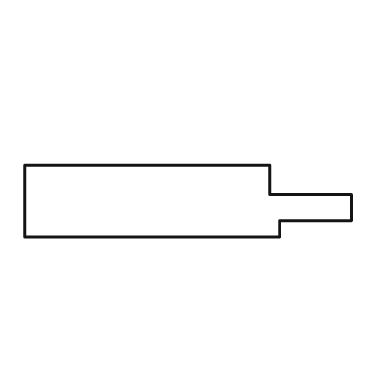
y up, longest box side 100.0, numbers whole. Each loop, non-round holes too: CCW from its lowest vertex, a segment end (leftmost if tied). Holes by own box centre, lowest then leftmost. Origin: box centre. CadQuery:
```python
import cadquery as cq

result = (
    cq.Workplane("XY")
    .moveTo(-50.0, -11.0)
    .lineTo(28.0, -11.0)
    .lineTo(28.0, -6.0)
    .lineTo(50.0, -6.0)
    .lineTo(50.0, 2.0)
    .lineTo(25.0, 2.0)
    .lineTo(25.0, 11.0)
    .lineTo(-50.0, 11.0)
    .close()
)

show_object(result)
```